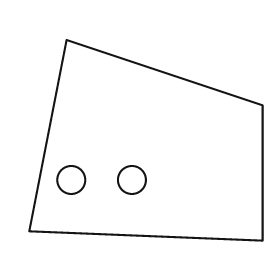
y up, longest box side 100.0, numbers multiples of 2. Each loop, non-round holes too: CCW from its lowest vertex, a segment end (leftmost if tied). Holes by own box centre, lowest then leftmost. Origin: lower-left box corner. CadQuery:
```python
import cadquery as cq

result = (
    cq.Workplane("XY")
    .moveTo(100.0, 0.0)
    .lineTo(100.0, 58.0)
    .lineTo(16.0, 86.0)
    .lineTo(0.0, 4.0)
    .close()
    .moveTo(18.0, 26.0)
    .circle(6.0)
    .moveTo(44.0, 26.0)
    .circle(6.0)
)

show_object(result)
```